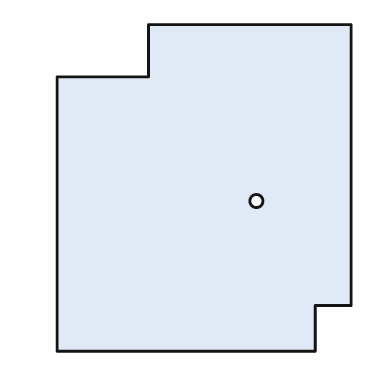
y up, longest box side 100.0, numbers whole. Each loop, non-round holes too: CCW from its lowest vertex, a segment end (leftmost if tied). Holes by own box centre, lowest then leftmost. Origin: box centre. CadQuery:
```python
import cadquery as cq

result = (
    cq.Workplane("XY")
    .moveTo(-45.0, -50.0)
    .lineTo(34.0, -50.0)
    .lineTo(34.0, -36.0)
    .lineTo(45.0, -36.0)
    .lineTo(45.0, 50.0)
    .lineTo(-17.0, 50.0)
    .lineTo(-17.0, 34.0)
    .lineTo(-45.0, 34.0)
    .close()
    .moveTo(16.0, -4.0)
    .circle(2.0)
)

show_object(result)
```